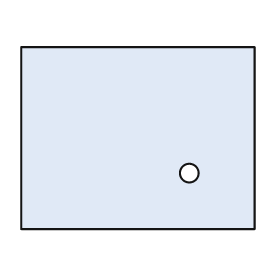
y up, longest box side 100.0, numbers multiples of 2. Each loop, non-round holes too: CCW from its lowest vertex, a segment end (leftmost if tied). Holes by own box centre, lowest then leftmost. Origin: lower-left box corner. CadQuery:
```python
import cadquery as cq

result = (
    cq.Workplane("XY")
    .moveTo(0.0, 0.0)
    .lineTo(100.0, 0.0)
    .lineTo(100.0, 78.0)
    .lineTo(0.0, 78.0)
    .close()
    .moveTo(72.0, 24.0)
    .circle(4.0)
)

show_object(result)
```